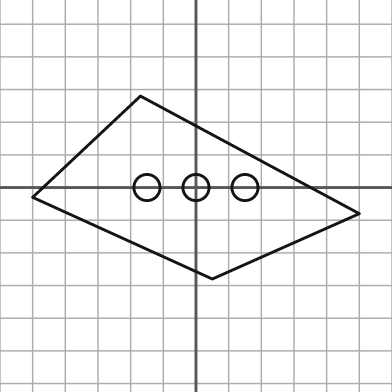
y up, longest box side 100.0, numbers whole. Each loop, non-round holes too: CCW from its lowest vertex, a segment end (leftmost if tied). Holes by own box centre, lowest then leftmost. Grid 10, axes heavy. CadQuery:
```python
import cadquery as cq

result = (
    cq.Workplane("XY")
    .moveTo(5.0, -28.0)
    .lineTo(50.0, -8.0)
    .lineTo(-17.0, 28.0)
    .lineTo(-50.0, -3.0)
    .close()
    .moveTo(-15.0, 0.0)
    .circle(4.0)
    .moveTo(0.0, 0.0)
    .circle(4.0)
    .moveTo(15.0, 0.0)
    .circle(4.0)
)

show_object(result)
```